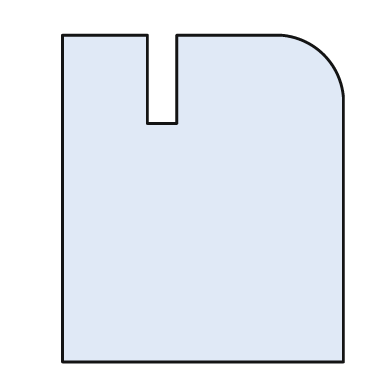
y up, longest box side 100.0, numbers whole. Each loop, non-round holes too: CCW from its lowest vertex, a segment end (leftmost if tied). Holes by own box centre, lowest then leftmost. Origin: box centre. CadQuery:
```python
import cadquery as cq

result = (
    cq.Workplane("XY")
    .moveTo(-43.0, -50.0)
    .lineTo(43.0, -50.0)
    .lineTo(43.0, 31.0)
    .threePointArc((37.0, 44.0), (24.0, 50.0))
    .lineTo(-8.0, 50.0)
    .lineTo(-8.0, 23.0)
    .lineTo(-17.0, 23.0)
    .lineTo(-17.0, 50.0)
    .lineTo(-43.0, 50.0)
    .close()
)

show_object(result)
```